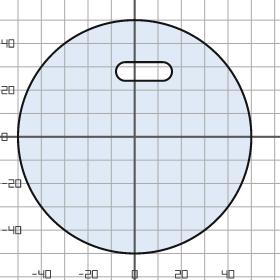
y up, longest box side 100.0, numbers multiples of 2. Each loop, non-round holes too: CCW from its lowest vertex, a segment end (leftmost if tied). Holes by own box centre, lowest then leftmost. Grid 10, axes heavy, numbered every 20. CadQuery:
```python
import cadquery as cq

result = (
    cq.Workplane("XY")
    .moveTo(0.0, 0.0)
    .circle(50.0)
    .moveTo(-4.0, 24.0)
    .lineTo(12.0, 24.0)
    .threePointArc((16.0, 28.0), (12.0, 32.0))
    .lineTo(-4.0, 32.0)
    .threePointArc((-8.0, 28.0), (-4.0, 24.0))
    .close()
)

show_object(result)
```